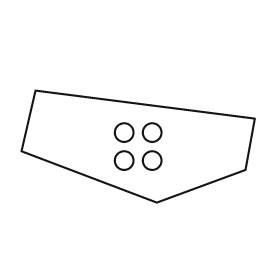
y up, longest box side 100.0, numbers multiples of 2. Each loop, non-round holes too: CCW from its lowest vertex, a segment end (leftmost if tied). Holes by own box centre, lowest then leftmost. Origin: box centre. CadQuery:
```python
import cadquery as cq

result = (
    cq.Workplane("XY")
    .moveTo(8.0, -24.0)
    .lineTo(46.0, -10.0)
    .lineTo(50.0, 12.0)
    .lineTo(-44.0, 24.0)
    .lineTo(-50.0, -2.0)
    .close()
    .moveTo(-6.0, -6.0)
    .circle(4.0)
    .moveTo(6.0, -6.0)
    .circle(4.0)
    .moveTo(-6.0, 6.0)
    .circle(4.0)
    .moveTo(6.0, 6.0)
    .circle(4.0)
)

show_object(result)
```